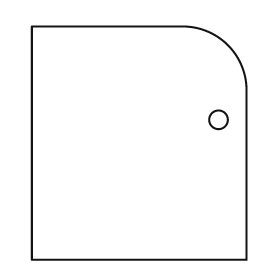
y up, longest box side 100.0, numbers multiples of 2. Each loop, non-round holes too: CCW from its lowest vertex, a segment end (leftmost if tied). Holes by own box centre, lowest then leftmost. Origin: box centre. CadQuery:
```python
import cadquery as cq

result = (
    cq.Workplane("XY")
    .moveTo(-46.0, -50.0)
    .lineTo(46.0, -50.0)
    .lineTo(46.0, 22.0)
    .threePointArc((38.0, 42.0), (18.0, 50.0))
    .lineTo(-46.0, 50.0)
    .close()
    .moveTo(34.0, 10.0)
    .circle(4.0)
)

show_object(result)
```